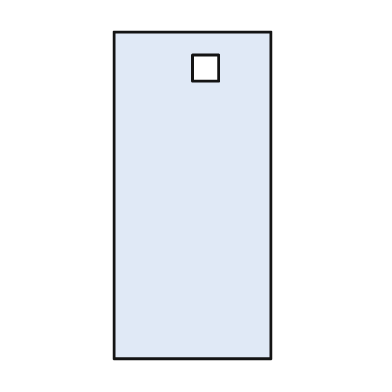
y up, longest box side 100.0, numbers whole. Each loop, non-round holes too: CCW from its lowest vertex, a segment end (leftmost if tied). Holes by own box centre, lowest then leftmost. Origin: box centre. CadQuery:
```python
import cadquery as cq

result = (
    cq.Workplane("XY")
    .moveTo(-24.0, -50.0)
    .lineTo(24.0, -50.0)
    .lineTo(24.0, 50.0)
    .lineTo(-24.0, 50.0)
    .close()
    .moveTo(0.0, 35.0)
    .lineTo(8.0, 35.0)
    .lineTo(8.0, 43.0)
    .lineTo(0.0, 43.0)
    .close()
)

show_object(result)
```